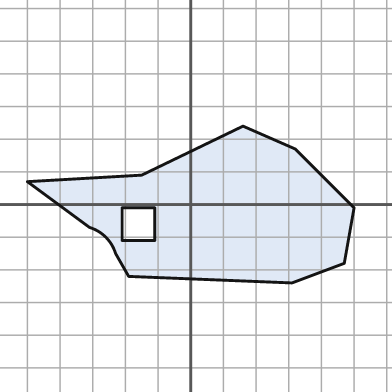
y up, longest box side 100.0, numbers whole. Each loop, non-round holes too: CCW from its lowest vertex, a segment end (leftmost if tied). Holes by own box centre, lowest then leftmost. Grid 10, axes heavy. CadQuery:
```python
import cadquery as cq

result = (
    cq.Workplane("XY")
    .moveTo(31.0, -24.0)
    .lineTo(47.0, -18.0)
    .lineTo(50.0, -1.0)
    .lineTo(32.0, 17.0)
    .lineTo(16.0, 24.0)
    .lineTo(-15.0, 9.0)
    .lineTo(-50.0, 7.0)
    .lineTo(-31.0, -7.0)
    .threePointArc((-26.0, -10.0), (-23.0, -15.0))
    .lineTo(-19.0, -22.0)
    .close()
    .moveTo(-21.0, -11.0)
    .lineTo(-11.0, -11.0)
    .lineTo(-11.0, -1.0)
    .lineTo(-21.0, -1.0)
    .close()
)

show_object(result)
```